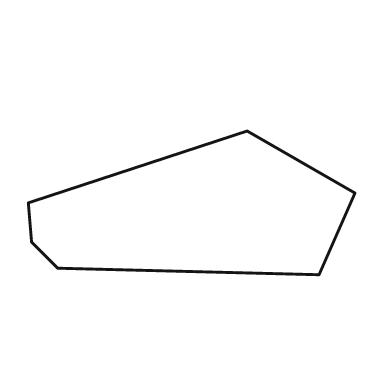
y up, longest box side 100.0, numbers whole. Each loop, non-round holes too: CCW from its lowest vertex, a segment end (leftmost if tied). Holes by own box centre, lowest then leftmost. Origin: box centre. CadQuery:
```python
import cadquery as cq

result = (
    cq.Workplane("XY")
    .moveTo(39.0, -22.0)
    .lineTo(50.0, 3.0)
    .lineTo(17.0, 22.0)
    .lineTo(-50.0, 0.0)
    .lineTo(-49.0, -12.0)
    .lineTo(-41.0, -20.0)
    .close()
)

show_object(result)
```